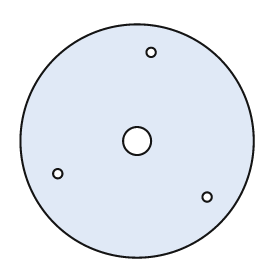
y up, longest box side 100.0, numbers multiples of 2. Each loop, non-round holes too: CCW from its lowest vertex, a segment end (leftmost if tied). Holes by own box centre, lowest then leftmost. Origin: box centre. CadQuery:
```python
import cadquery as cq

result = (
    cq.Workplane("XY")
    .moveTo(0.0, 0.0)
    .circle(50.0)
    .moveTo(30.0, -24.0)
    .circle(2.0)
    .moveTo(-34.0, -14.0)
    .circle(2.0)
    .moveTo(0.0, 0.0)
    .circle(6.0)
    .moveTo(6.0, 38.0)
    .circle(2.0)
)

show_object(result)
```